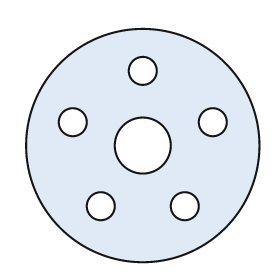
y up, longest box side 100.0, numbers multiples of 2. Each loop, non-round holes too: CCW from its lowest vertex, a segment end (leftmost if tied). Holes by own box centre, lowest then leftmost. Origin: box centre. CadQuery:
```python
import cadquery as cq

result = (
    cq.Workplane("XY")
    .moveTo(0.0, 0.0)
    .circle(50.0)
    .moveTo(-18.0, -26.0)
    .circle(6.0)
    .moveTo(18.0, -26.0)
    .circle(6.0)
    .moveTo(0.0, 0.0)
    .circle(12.0)
    .moveTo(-30.0, 10.0)
    .circle(6.0)
    .moveTo(30.0, 10.0)
    .circle(6.0)
    .moveTo(0.0, 32.0)
    .circle(6.0)
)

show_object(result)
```